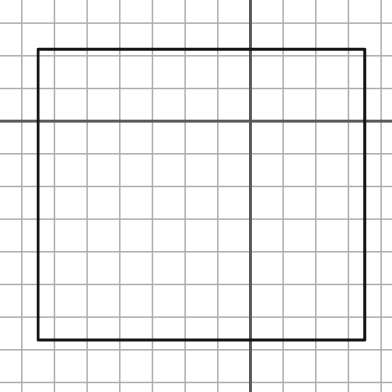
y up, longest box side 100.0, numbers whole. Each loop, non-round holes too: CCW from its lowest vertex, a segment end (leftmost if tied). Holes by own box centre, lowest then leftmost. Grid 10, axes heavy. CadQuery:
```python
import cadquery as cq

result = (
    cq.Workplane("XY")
    .moveTo(-65.0, -67.0)
    .lineTo(35.0, -67.0)
    .lineTo(35.0, 22.0)
    .lineTo(-65.0, 22.0)
    .close()
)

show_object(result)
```